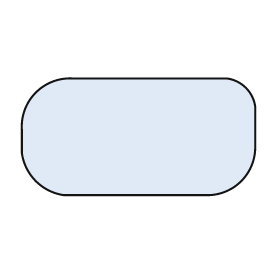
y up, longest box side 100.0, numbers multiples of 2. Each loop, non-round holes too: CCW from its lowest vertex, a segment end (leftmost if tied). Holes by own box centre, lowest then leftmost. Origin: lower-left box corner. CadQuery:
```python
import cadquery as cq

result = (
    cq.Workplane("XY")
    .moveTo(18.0, 0.0)
    .lineTo(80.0, 0.0)
    .threePointArc((94.0, 6.0), (100.0, 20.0))
    .lineTo(100.0, 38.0)
    .threePointArc((96.0, 46.0), (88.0, 50.0))
    .lineTo(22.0, 50.0)
    .threePointArc((6.0, 44.0), (0.0, 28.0))
    .lineTo(0.0, 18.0)
    .threePointArc((6.0, 6.0), (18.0, 0.0))
    .close()
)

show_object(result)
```